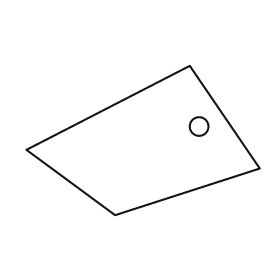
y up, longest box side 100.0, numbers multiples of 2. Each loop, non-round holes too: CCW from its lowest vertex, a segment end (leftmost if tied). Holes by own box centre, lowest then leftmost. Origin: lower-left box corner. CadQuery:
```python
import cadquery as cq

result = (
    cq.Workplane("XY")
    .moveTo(38.0, 0.0)
    .lineTo(100.0, 20.0)
    .lineTo(70.0, 64.0)
    .lineTo(0.0, 28.0)
    .close()
    .moveTo(74.0, 38.0)
    .circle(4.0)
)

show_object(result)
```